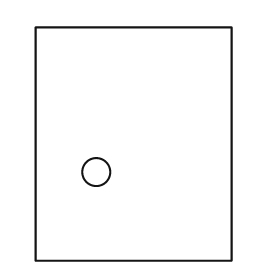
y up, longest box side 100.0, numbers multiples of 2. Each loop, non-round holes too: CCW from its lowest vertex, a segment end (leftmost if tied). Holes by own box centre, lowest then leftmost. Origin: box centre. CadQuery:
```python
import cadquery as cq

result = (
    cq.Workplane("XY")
    .moveTo(-42.0, -50.0)
    .lineTo(42.0, -50.0)
    .lineTo(42.0, 50.0)
    .lineTo(-42.0, 50.0)
    .close()
    .moveTo(-16.0, -12.0)
    .circle(6.0)
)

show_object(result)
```